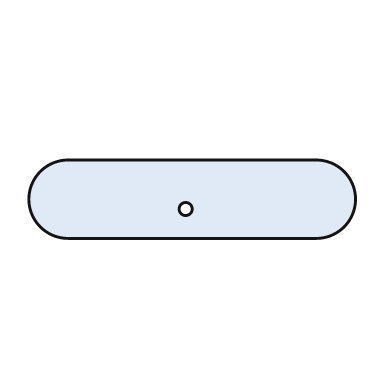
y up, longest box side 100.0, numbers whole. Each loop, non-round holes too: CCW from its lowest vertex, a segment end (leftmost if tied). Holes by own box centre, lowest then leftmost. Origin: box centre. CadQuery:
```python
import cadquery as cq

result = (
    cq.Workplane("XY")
    .moveTo(-38.0, -12.0)
    .lineTo(38.0, -12.0)
    .threePointArc((50.0, 0.0), (38.0, 12.0))
    .lineTo(-38.0, 12.0)
    .threePointArc((-50.0, 0.0), (-38.0, -12.0))
    .close()
    .moveTo(-2.0, -3.0)
    .circle(2.0)
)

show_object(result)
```